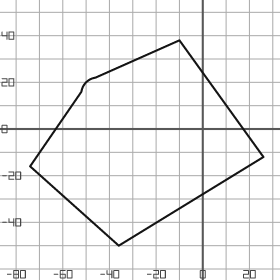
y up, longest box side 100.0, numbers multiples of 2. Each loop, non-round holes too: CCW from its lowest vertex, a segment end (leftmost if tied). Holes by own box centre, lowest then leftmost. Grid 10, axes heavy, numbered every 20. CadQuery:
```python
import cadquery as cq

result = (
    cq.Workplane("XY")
    .moveTo(-36.0, -50.0)
    .lineTo(26.0, -12.0)
    .lineTo(-10.0, 38.0)
    .lineTo(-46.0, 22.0)
    .threePointArc((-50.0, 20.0), (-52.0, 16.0))
    .lineTo(-74.0, -16.0)
    .close()
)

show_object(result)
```